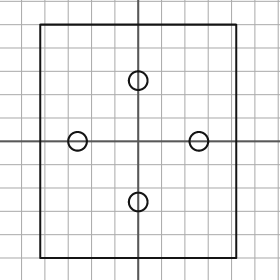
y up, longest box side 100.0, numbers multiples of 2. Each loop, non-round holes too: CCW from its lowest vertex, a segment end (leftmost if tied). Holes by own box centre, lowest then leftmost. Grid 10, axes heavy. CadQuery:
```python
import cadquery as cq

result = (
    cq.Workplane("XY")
    .moveTo(-42.0, -50.0)
    .lineTo(42.0, -50.0)
    .lineTo(42.0, 50.0)
    .lineTo(-42.0, 50.0)
    .close()
    .moveTo(0.0, -26.0)
    .circle(4.0)
    .moveTo(-26.0, 0.0)
    .circle(4.0)
    .moveTo(26.0, 0.0)
    .circle(4.0)
    .moveTo(0.0, 26.0)
    .circle(4.0)
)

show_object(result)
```